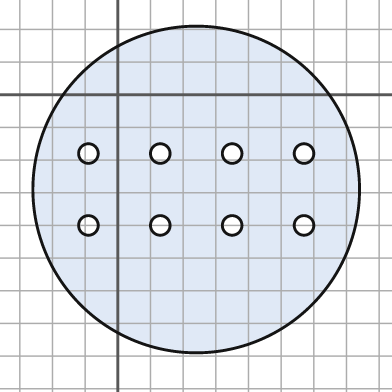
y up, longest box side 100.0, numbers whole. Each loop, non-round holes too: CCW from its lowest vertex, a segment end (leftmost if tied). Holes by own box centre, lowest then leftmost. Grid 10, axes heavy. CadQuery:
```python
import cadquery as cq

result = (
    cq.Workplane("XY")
    .moveTo(24.0, -29.0)
    .circle(50.0)
    .moveTo(-9.0, -40.0)
    .circle(3.0)
    .moveTo(13.0, -40.0)
    .circle(3.0)
    .moveTo(35.0, -40.0)
    .circle(3.0)
    .moveTo(57.0, -40.0)
    .circle(3.0)
    .moveTo(-9.0, -18.0)
    .circle(3.0)
    .moveTo(13.0, -18.0)
    .circle(3.0)
    .moveTo(35.0, -18.0)
    .circle(3.0)
    .moveTo(57.0, -18.0)
    .circle(3.0)
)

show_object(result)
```